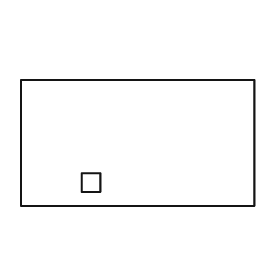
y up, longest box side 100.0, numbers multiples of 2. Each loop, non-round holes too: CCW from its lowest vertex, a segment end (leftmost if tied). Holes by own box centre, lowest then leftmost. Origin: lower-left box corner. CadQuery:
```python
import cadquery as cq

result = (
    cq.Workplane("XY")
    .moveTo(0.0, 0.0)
    .lineTo(100.0, 0.0)
    .lineTo(100.0, 54.0)
    .lineTo(0.0, 54.0)
    .close()
    .moveTo(26.0, 6.0)
    .lineTo(34.0, 6.0)
    .lineTo(34.0, 14.0)
    .lineTo(26.0, 14.0)
    .close()
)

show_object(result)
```